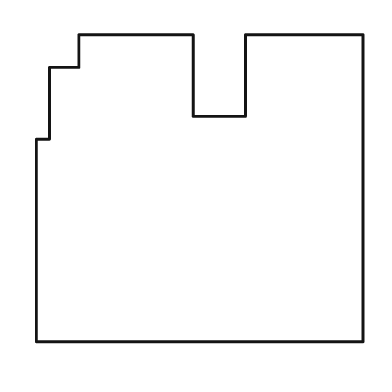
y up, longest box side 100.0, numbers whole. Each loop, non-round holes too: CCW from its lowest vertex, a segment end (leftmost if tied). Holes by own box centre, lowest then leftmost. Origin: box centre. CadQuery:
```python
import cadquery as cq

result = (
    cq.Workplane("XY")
    .moveTo(-50.0, -47.0)
    .lineTo(50.0, -47.0)
    .lineTo(50.0, 47.0)
    .lineTo(14.0, 47.0)
    .lineTo(14.0, 22.0)
    .lineTo(-2.0, 22.0)
    .lineTo(-2.0, 47.0)
    .lineTo(-37.0, 47.0)
    .lineTo(-37.0, 37.0)
    .lineTo(-46.0, 37.0)
    .lineTo(-46.0, 15.0)
    .lineTo(-50.0, 15.0)
    .close()
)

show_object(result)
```